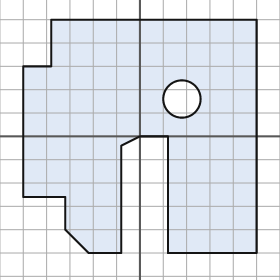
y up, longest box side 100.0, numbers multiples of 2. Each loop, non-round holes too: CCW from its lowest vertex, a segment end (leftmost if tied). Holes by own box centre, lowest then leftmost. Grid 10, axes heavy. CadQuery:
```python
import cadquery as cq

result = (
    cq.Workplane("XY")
    .moveTo(-22.0, -50.0)
    .lineTo(-8.0, -50.0)
    .lineTo(-8.0, -4.0)
    .lineTo(0.0, 0.0)
    .lineTo(12.0, 0.0)
    .lineTo(12.0, -50.0)
    .lineTo(50.0, -50.0)
    .lineTo(50.0, 50.0)
    .lineTo(-38.0, 50.0)
    .lineTo(-38.0, 30.0)
    .lineTo(-50.0, 30.0)
    .lineTo(-50.0, -26.0)
    .lineTo(-32.0, -26.0)
    .lineTo(-32.0, -40.0)
    .close()
    .moveTo(18.0, 16.0)
    .circle(8.0)
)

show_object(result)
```